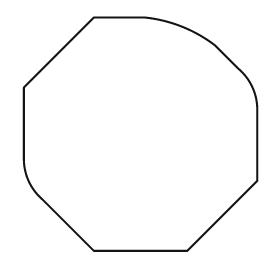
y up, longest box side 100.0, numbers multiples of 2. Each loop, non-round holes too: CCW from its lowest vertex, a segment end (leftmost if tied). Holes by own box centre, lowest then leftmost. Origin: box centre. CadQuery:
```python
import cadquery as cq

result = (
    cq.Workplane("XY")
    .moveTo(-20.0, -50.0)
    .lineTo(20.0, -50.0)
    .lineTo(50.0, -20.0)
    .lineTo(50.0, 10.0)
    .threePointArc((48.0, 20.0), (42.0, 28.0))
    .lineTo(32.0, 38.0)
    .threePointArc((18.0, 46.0), (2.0, 50.0))
    .lineTo(-20.0, 50.0)
    .lineTo(-50.0, 20.0)
    .lineTo(-50.0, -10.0)
    .threePointArc((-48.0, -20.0), (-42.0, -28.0))
    .close()
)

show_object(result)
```